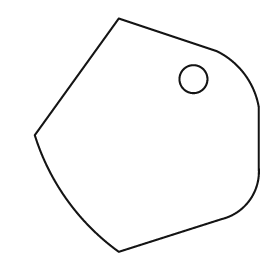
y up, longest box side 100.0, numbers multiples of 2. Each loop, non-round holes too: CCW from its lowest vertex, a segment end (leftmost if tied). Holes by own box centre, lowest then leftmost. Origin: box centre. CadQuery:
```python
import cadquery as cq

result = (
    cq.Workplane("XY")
    .moveTo(-12.0, -50.0)
    .lineTo(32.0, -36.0)
    .threePointArc((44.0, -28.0), (48.0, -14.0))
    .lineTo(48.0, 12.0)
    .threePointArc((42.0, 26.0), (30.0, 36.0))
    .lineTo(-12.0, 50.0)
    .lineTo(-48.0, 0.0)
    .threePointArc((-34.0, -28.0), (-12.0, -50.0))
    .close()
    .moveTo(20.0, 24.0)
    .circle(6.0)
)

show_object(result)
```